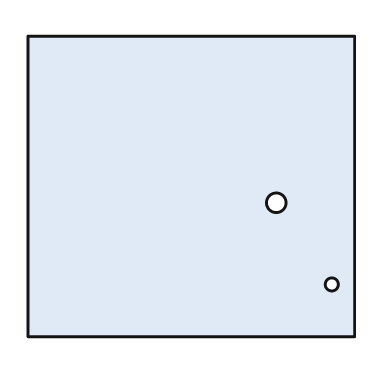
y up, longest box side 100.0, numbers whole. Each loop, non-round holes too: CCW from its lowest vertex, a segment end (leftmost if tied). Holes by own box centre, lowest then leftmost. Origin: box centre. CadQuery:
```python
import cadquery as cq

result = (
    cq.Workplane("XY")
    .moveTo(-50.0, -46.0)
    .lineTo(50.0, -46.0)
    .lineTo(50.0, 46.0)
    .lineTo(-50.0, 46.0)
    .close()
    .moveTo(43.0, -30.0)
    .circle(2.0)
    .moveTo(26.0, -5.0)
    .circle(3.0)
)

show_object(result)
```